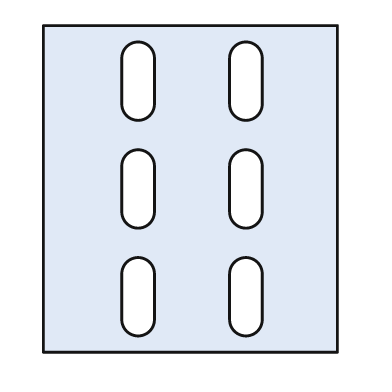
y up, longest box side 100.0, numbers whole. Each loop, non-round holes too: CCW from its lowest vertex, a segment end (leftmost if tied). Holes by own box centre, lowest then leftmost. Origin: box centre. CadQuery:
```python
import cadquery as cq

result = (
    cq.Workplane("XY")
    .moveTo(-45.0, -50.0)
    .lineTo(45.0, -50.0)
    .lineTo(45.0, 50.0)
    .lineTo(-45.0, 50.0)
    .close()
    .moveTo(-21.0, -40.0)
    .threePointArc((-16.0, -45.0), (-11.0, -40.0))
    .lineTo(-11.0, -26.0)
    .threePointArc((-16.0, -21.0), (-21.0, -26.0))
    .close()
    .moveTo(12.0, -40.0)
    .threePointArc((17.0, -45.0), (22.0, -40.0))
    .lineTo(22.0, -26.0)
    .threePointArc((17.0, -21.0), (12.0, -26.0))
    .close()
    .moveTo(-21.0, -7.0)
    .threePointArc((-16.0, -12.0), (-11.0, -7.0))
    .lineTo(-11.0, 7.0)
    .threePointArc((-16.0, 12.0), (-21.0, 7.0))
    .close()
    .moveTo(12.0, -7.0)
    .threePointArc((17.0, -12.0), (22.0, -7.0))
    .lineTo(22.0, 7.0)
    .threePointArc((17.0, 12.0), (12.0, 7.0))
    .close()
    .moveTo(-21.0, 26.0)
    .threePointArc((-16.0, 21.0), (-11.0, 26.0))
    .lineTo(-11.0, 40.0)
    .threePointArc((-16.0, 45.0), (-21.0, 40.0))
    .close()
    .moveTo(12.0, 26.0)
    .threePointArc((17.0, 21.0), (22.0, 26.0))
    .lineTo(22.0, 40.0)
    .threePointArc((17.0, 45.0), (12.0, 40.0))
    .close()
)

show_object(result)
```